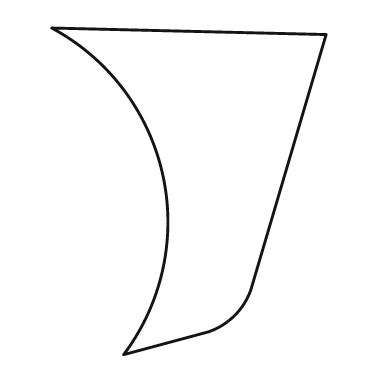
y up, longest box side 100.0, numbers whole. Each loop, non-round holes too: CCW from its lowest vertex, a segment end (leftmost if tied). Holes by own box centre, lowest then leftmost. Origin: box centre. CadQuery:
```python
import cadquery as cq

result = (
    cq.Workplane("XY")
    .moveTo(-20.0, -50.0)
    .lineTo(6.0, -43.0)
    .threePointArc((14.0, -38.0), (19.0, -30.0))
    .lineTo(42.0, 48.0)
    .lineTo(-42.0, 50.0)
    .threePointArc((-8.0, 5.0), (-20.0, -50.0))
    .close()
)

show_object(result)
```